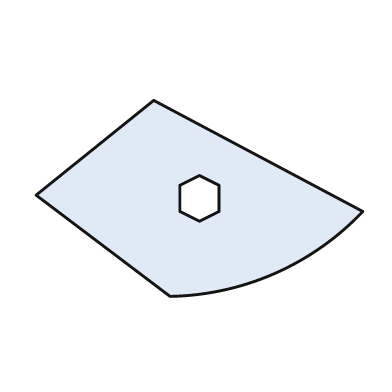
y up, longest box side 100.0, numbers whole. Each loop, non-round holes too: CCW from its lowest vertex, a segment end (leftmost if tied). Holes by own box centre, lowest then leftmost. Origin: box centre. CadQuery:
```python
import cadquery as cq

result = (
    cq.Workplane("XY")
    .moveTo(-9.0, -30.0)
    .threePointArc((23.0, -23.0), (50.0, -4.0))
    .lineTo(-14.0, 30.0)
    .lineTo(-50.0, 1.0)
    .close()
    .moveTo(0.0, -7.0)
    .lineTo(6.0, -4.0)
    .lineTo(6.0, 4.0)
    .lineTo(0.0, 7.0)
    .lineTo(-6.0, 4.0)
    .lineTo(-6.0, -4.0)
    .close()
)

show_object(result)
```